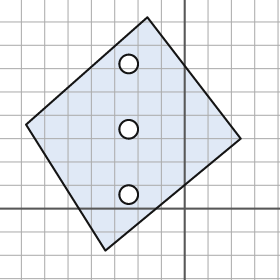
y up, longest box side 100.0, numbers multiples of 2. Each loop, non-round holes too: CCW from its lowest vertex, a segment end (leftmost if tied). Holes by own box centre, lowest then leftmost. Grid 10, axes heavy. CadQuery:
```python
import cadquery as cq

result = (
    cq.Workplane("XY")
    .moveTo(-34.0, -18.0)
    .lineTo(24.0, 30.0)
    .lineTo(-16.0, 82.0)
    .lineTo(-68.0, 36.0)
    .close()
    .moveTo(-24.0, 6.0)
    .circle(4.0)
    .moveTo(-24.0, 34.0)
    .circle(4.0)
    .moveTo(-24.0, 62.0)
    .circle(4.0)
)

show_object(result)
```